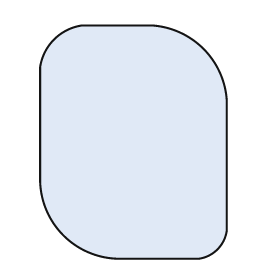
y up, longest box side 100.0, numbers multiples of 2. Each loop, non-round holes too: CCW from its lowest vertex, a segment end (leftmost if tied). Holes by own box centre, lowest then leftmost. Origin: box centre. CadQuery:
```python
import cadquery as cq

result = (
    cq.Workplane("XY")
    .moveTo(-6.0, -50.0)
    .lineTo(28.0, -50.0)
    .threePointArc((36.0, -46.0), (40.0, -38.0))
    .lineTo(40.0, 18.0)
    .threePointArc((30.0, 40.0), (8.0, 50.0))
    .lineTo(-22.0, 50.0)
    .threePointArc((-34.0, 44.0), (-40.0, 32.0))
    .lineTo(-40.0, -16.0)
    .threePointArc((-30.0, -40.0), (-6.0, -50.0))
    .close()
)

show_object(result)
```